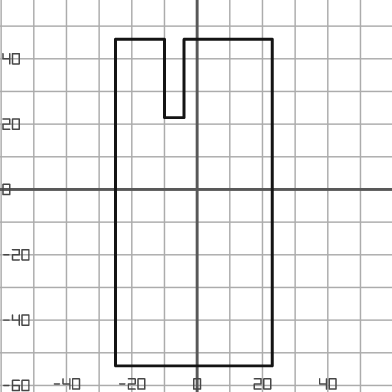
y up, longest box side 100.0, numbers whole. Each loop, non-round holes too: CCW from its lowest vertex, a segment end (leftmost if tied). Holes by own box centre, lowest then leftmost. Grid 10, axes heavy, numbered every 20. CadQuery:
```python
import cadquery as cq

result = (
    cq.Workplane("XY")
    .moveTo(-25.0, -54.0)
    .lineTo(23.0, -54.0)
    .lineTo(23.0, 46.0)
    .lineTo(-4.0, 46.0)
    .lineTo(-4.0, 22.0)
    .lineTo(-10.0, 22.0)
    .lineTo(-10.0, 46.0)
    .lineTo(-25.0, 46.0)
    .close()
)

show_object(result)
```